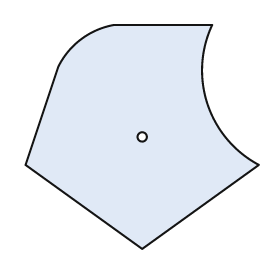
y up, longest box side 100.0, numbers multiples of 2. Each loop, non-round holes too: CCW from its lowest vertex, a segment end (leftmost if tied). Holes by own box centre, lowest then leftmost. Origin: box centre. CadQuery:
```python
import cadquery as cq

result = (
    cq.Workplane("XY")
    .moveTo(0.0, -48.0)
    .lineTo(50.0, -12.0)
    .threePointArc((28.0, 14.0), (30.0, 48.0))
    .lineTo(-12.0, 48.0)
    .threePointArc((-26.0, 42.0), (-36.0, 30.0))
    .lineTo(-50.0, -12.0)
    .close()
    .moveTo(0.0, 0.0)
    .circle(2.0)
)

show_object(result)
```